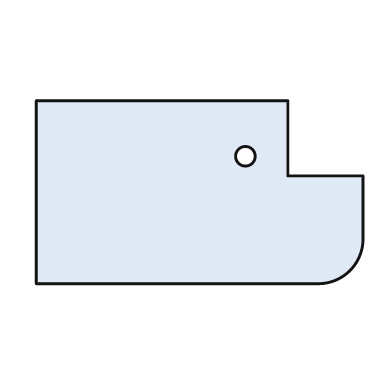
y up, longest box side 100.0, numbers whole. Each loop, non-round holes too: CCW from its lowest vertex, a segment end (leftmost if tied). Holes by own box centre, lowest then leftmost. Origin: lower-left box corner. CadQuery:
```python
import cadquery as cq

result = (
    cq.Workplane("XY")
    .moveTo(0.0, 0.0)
    .lineTo(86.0, 0.0)
    .threePointArc((96.0, 4.0), (100.0, 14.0))
    .lineTo(100.0, 33.0)
    .lineTo(77.0, 33.0)
    .lineTo(77.0, 56.0)
    .lineTo(0.0, 56.0)
    .close()
    .moveTo(64.0, 39.0)
    .circle(3.0)
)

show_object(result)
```